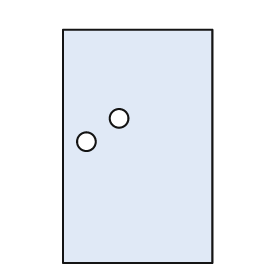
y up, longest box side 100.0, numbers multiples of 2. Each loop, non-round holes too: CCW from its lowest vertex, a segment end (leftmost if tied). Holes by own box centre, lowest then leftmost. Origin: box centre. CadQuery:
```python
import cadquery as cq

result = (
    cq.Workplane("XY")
    .moveTo(-32.0, -50.0)
    .lineTo(32.0, -50.0)
    .lineTo(32.0, 50.0)
    .lineTo(-32.0, 50.0)
    .close()
    .moveTo(-22.0, 2.0)
    .circle(4.0)
    .moveTo(-8.0, 12.0)
    .circle(4.0)
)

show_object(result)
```